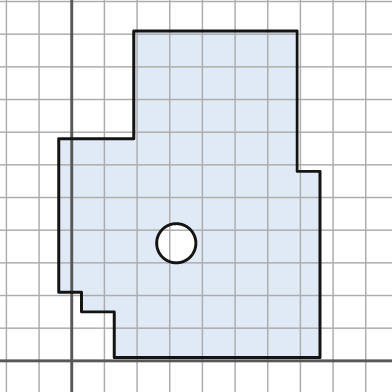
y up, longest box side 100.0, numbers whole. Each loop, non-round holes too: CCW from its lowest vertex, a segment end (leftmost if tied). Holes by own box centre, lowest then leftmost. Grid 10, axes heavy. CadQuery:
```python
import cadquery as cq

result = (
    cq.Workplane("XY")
    .moveTo(13.0, 1.0)
    .lineTo(76.0, 1.0)
    .lineTo(76.0, 58.0)
    .lineTo(69.0, 58.0)
    .lineTo(69.0, 101.0)
    .lineTo(19.0, 101.0)
    .lineTo(19.0, 68.0)
    .lineTo(-4.0, 68.0)
    .lineTo(-4.0, 21.0)
    .lineTo(3.0, 21.0)
    .lineTo(3.0, 15.0)
    .lineTo(13.0, 15.0)
    .close()
    .moveTo(32.0, 36.0)
    .circle(6.0)
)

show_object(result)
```